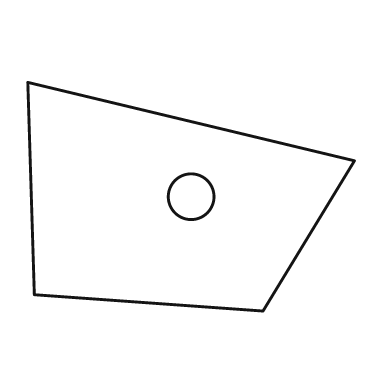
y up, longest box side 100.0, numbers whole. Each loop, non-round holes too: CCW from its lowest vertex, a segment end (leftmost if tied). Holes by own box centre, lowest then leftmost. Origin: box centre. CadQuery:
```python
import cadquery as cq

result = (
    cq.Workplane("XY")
    .moveTo(22.0, -35.0)
    .lineTo(50.0, 11.0)
    .lineTo(-50.0, 35.0)
    .lineTo(-48.0, -30.0)
    .close()
    .moveTo(0.0, 0.0)
    .circle(7.0)
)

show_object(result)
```